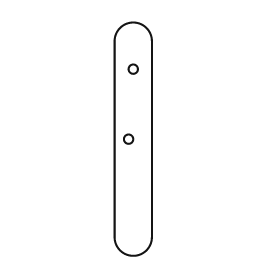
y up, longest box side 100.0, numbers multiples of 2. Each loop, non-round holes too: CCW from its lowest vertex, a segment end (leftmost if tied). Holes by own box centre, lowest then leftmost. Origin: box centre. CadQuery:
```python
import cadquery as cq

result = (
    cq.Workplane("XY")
    .moveTo(-8.0, -42.0)
    .threePointArc((0.0, -50.0), (8.0, -42.0))
    .lineTo(8.0, 42.0)
    .threePointArc((0.0, 50.0), (-8.0, 42.0))
    .close()
    .moveTo(-2.0, 0.0)
    .circle(2.0)
    .moveTo(0.0, 30.0)
    .circle(2.0)
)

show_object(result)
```